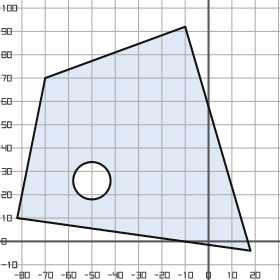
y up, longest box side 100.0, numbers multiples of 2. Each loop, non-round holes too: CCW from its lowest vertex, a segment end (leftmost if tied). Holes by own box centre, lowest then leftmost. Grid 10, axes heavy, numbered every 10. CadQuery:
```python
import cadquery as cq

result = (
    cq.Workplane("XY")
    .moveTo(18.0, -4.0)
    .lineTo(-10.0, 92.0)
    .lineTo(-70.0, 70.0)
    .lineTo(-82.0, 10.0)
    .close()
    .moveTo(-50.0, 26.0)
    .circle(8.0)
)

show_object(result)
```